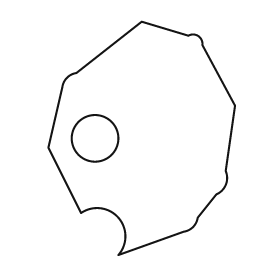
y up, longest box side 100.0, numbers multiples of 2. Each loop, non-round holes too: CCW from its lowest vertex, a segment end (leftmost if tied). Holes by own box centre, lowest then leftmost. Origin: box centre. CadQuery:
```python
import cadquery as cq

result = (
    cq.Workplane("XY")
    .moveTo(-10.0, -50.0)
    .lineTo(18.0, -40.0)
    .threePointArc((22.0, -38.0), (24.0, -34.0))
    .lineTo(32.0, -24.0)
    .threePointArc((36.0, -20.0), (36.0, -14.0))
    .lineTo(40.0, 14.0)
    .lineTo(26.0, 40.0)
    .threePointArc((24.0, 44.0), (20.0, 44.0))
    .lineTo(0.0, 50.0)
    .lineTo(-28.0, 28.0)
    .threePointArc((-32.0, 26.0), (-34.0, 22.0))
    .lineTo(-40.0, -4.0)
    .lineTo(-26.0, -32.0)
    .threePointArc((-10.0, -34.0), (-10.0, -50.0))
    .close()
    .moveTo(-20.0, 0.0)
    .circle(10.0)
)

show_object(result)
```